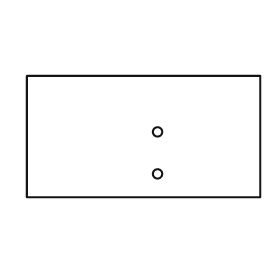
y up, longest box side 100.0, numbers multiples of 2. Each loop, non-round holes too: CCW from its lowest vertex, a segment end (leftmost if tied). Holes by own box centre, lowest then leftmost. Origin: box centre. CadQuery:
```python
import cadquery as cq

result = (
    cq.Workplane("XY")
    .moveTo(-50.0, -26.0)
    .lineTo(50.0, -26.0)
    .lineTo(50.0, 26.0)
    .lineTo(-50.0, 26.0)
    .close()
    .moveTo(6.0, -16.0)
    .circle(2.0)
    .moveTo(6.0, 2.0)
    .circle(2.0)
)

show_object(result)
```